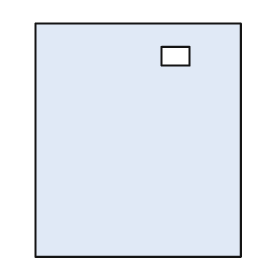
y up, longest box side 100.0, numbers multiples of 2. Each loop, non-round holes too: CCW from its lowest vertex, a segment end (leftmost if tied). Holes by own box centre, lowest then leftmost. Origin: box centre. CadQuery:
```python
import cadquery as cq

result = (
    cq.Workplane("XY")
    .moveTo(-44.0, -50.0)
    .lineTo(44.0, -50.0)
    .lineTo(44.0, 50.0)
    .lineTo(-44.0, 50.0)
    .close()
    .moveTo(10.0, 32.0)
    .lineTo(22.0, 32.0)
    .lineTo(22.0, 40.0)
    .lineTo(10.0, 40.0)
    .close()
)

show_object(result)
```